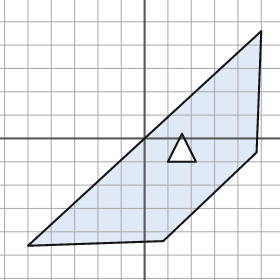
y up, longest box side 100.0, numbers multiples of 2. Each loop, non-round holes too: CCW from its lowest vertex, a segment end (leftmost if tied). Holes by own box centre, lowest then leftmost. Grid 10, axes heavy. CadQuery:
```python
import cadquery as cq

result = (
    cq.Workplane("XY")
    .moveTo(-50.0, -46.0)
    .lineTo(8.0, -44.0)
    .lineTo(48.0, -6.0)
    .lineTo(50.0, 46.0)
    .close()
    .moveTo(10.0, -10.0)
    .lineTo(22.0, -10.0)
    .lineTo(16.0, 2.0)
    .close()
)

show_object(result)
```